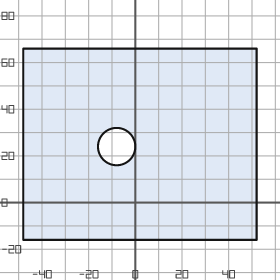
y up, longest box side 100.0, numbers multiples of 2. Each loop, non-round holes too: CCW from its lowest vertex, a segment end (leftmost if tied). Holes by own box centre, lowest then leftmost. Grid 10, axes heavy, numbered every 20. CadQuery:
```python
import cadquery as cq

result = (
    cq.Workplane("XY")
    .moveTo(-48.0, -16.0)
    .lineTo(52.0, -16.0)
    .lineTo(52.0, 66.0)
    .lineTo(-48.0, 66.0)
    .close()
    .moveTo(-8.0, 24.0)
    .circle(8.0)
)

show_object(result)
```